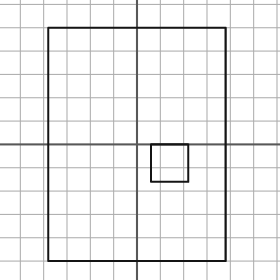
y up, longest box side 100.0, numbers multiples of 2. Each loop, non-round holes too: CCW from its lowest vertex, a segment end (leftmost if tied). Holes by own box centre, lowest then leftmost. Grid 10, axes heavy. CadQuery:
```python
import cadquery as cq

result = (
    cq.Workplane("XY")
    .moveTo(-38.0, -50.0)
    .lineTo(38.0, -50.0)
    .lineTo(38.0, 50.0)
    .lineTo(-38.0, 50.0)
    .close()
    .moveTo(6.0, -16.0)
    .lineTo(22.0, -16.0)
    .lineTo(22.0, 0.0)
    .lineTo(6.0, 0.0)
    .close()
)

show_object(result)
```